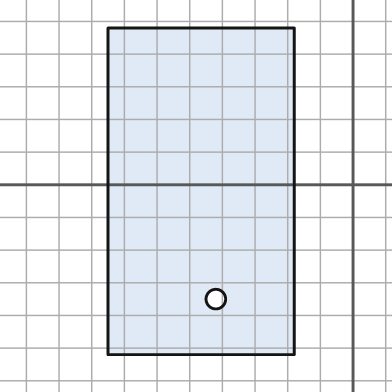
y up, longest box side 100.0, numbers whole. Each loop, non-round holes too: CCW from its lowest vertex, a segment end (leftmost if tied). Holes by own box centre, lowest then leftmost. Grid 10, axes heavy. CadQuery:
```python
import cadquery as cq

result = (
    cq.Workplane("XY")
    .moveTo(-75.0, -52.0)
    .lineTo(-18.0, -52.0)
    .lineTo(-18.0, 48.0)
    .lineTo(-75.0, 48.0)
    .close()
    .moveTo(-42.0, -35.0)
    .circle(3.0)
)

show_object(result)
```